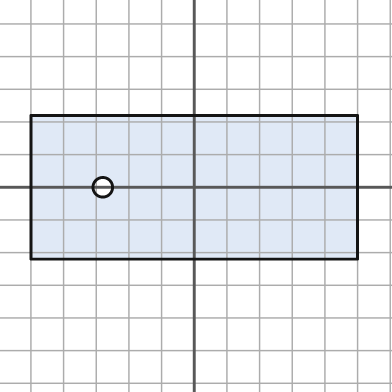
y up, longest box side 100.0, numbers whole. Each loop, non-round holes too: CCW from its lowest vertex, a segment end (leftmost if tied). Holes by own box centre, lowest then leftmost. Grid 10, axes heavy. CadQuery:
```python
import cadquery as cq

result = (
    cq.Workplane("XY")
    .moveTo(-50.0, -22.0)
    .lineTo(50.0, -22.0)
    .lineTo(50.0, 22.0)
    .lineTo(-50.0, 22.0)
    .close()
    .moveTo(-28.0, 0.0)
    .circle(3.0)
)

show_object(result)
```